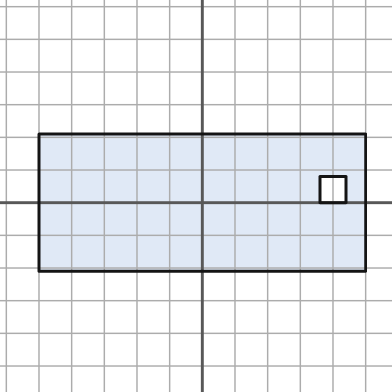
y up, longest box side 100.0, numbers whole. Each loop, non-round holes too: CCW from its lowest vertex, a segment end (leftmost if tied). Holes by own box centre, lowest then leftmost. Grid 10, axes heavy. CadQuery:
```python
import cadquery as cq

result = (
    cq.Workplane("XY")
    .moveTo(-50.0, -21.0)
    .lineTo(50.0, -21.0)
    .lineTo(50.0, 21.0)
    .lineTo(-50.0, 21.0)
    .close()
    .moveTo(36.0, 0.0)
    .lineTo(44.0, 0.0)
    .lineTo(44.0, 8.0)
    .lineTo(36.0, 8.0)
    .close()
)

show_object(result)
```